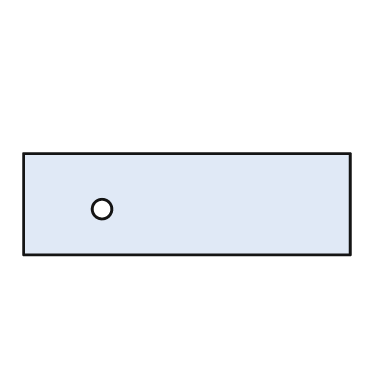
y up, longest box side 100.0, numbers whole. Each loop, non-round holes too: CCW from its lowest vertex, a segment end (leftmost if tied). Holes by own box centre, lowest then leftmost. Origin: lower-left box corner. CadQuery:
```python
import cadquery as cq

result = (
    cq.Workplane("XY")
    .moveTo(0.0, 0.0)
    .lineTo(100.0, 0.0)
    .lineTo(100.0, 31.0)
    .lineTo(0.0, 31.0)
    .close()
    .moveTo(24.0, 14.0)
    .circle(3.0)
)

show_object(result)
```